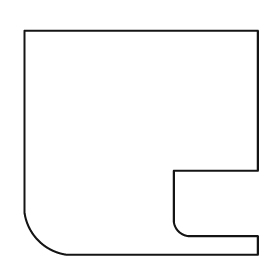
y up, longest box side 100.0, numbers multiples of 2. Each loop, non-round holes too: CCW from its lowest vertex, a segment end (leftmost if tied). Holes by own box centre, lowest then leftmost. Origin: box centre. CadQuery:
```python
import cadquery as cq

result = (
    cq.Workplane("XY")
    .moveTo(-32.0, -48.0)
    .lineTo(50.0, -48.0)
    .lineTo(50.0, -40.0)
    .lineTo(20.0, -40.0)
    .threePointArc((16.0, -38.0), (14.0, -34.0))
    .lineTo(14.0, -12.0)
    .lineTo(50.0, -12.0)
    .lineTo(50.0, 48.0)
    .lineTo(-50.0, 48.0)
    .lineTo(-50.0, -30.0)
    .threePointArc((-44.0, -42.0), (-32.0, -48.0))
    .close()
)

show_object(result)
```